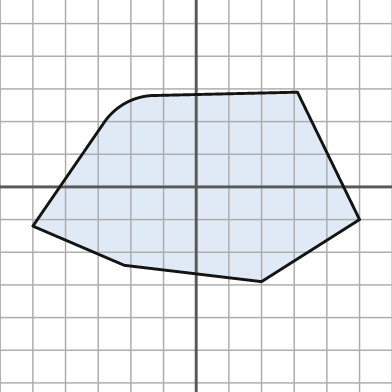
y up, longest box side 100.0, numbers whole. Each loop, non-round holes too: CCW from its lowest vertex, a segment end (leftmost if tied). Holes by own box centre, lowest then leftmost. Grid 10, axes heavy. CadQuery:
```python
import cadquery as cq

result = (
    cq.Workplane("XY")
    .moveTo(20.0, -29.0)
    .lineTo(50.0, -10.0)
    .lineTo(31.0, 29.0)
    .lineTo(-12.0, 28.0)
    .threePointArc((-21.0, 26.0), (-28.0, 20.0))
    .lineTo(-50.0, -12.0)
    .lineTo(-22.0, -24.0)
    .close()
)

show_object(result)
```